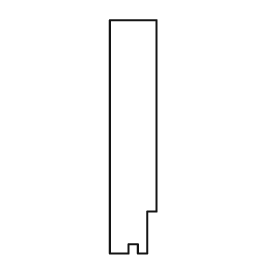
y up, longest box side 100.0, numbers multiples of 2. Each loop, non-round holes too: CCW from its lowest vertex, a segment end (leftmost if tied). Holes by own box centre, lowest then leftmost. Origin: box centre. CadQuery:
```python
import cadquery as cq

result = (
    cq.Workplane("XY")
    .moveTo(-10.0, -50.0)
    .lineTo(-2.0, -50.0)
    .lineTo(-2.0, -46.0)
    .lineTo(2.0, -46.0)
    .lineTo(2.0, -50.0)
    .lineTo(6.0, -50.0)
    .lineTo(6.0, -32.0)
    .lineTo(10.0, -32.0)
    .lineTo(10.0, 50.0)
    .lineTo(-10.0, 50.0)
    .close()
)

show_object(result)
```